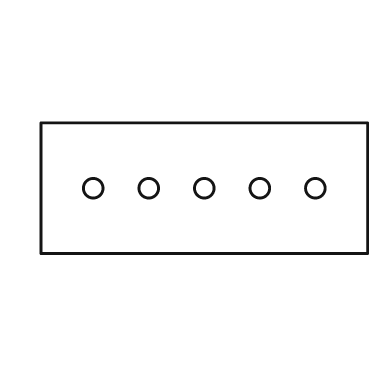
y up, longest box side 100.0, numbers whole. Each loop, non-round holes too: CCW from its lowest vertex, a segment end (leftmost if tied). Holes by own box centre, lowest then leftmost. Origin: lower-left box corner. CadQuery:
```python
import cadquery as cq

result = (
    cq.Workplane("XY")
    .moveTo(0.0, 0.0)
    .lineTo(100.0, 0.0)
    .lineTo(100.0, 40.0)
    .lineTo(0.0, 40.0)
    .close()
    .moveTo(16.0, 20.0)
    .circle(3.0)
    .moveTo(33.0, 20.0)
    .circle(3.0)
    .moveTo(50.0, 20.0)
    .circle(3.0)
    .moveTo(67.0, 20.0)
    .circle(3.0)
    .moveTo(84.0, 20.0)
    .circle(3.0)
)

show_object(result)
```